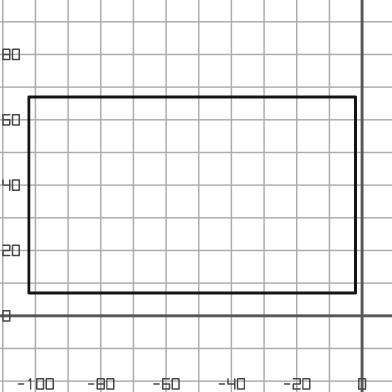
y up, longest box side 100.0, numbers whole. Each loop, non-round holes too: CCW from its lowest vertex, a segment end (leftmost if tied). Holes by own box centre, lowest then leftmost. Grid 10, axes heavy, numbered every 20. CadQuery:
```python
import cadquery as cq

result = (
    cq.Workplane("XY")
    .moveTo(-102.0, 7.0)
    .lineTo(-2.0, 7.0)
    .lineTo(-2.0, 67.0)
    .lineTo(-102.0, 67.0)
    .close()
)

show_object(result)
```